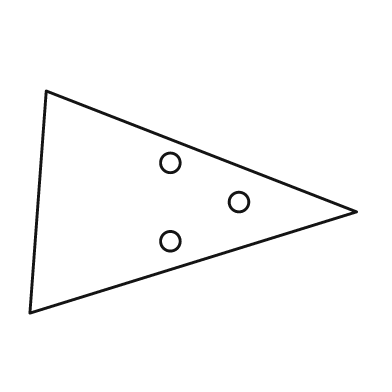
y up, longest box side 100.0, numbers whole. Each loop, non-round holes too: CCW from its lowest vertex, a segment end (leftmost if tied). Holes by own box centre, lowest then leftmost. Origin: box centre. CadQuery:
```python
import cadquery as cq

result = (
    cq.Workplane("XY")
    .moveTo(-50.0, -34.0)
    .lineTo(50.0, -3.0)
    .lineTo(-45.0, 34.0)
    .close()
    .moveTo(-7.0, -12.0)
    .circle(3.0)
    .moveTo(14.0, 0.0)
    .circle(3.0)
    .moveTo(-7.0, 12.0)
    .circle(3.0)
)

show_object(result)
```